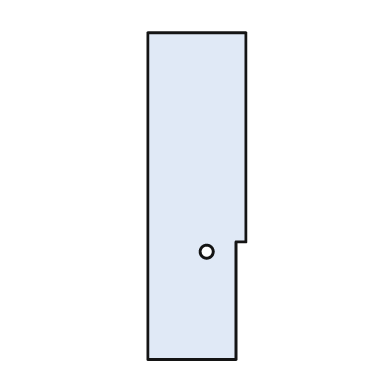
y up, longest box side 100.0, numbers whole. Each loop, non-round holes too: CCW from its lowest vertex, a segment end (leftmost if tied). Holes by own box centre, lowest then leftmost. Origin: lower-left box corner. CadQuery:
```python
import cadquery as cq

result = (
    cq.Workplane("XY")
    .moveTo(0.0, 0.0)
    .lineTo(27.0, 0.0)
    .lineTo(27.0, 36.0)
    .lineTo(30.0, 36.0)
    .lineTo(30.0, 100.0)
    .lineTo(0.0, 100.0)
    .close()
    .moveTo(18.0, 33.0)
    .circle(2.0)
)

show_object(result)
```